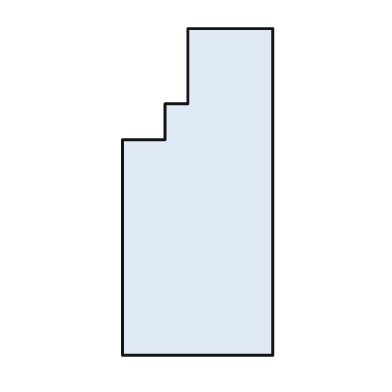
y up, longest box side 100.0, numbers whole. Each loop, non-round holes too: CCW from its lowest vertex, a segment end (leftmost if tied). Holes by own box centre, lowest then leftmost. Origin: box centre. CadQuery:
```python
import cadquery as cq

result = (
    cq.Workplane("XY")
    .moveTo(-23.0, -50.0)
    .lineTo(23.0, -50.0)
    .lineTo(23.0, 50.0)
    .lineTo(-3.0, 50.0)
    .lineTo(-3.0, 27.0)
    .lineTo(-10.0, 27.0)
    .lineTo(-10.0, 16.0)
    .lineTo(-23.0, 16.0)
    .close()
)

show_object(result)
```